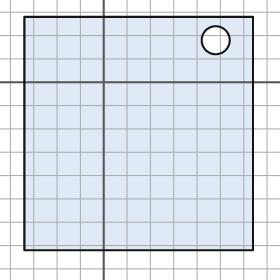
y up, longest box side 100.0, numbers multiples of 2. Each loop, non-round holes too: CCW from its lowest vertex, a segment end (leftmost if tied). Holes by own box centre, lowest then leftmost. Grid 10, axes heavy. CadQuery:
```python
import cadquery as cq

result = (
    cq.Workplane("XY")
    .moveTo(-34.0, -72.0)
    .lineTo(64.0, -72.0)
    .lineTo(64.0, 28.0)
    .lineTo(-34.0, 28.0)
    .close()
    .moveTo(48.0, 18.0)
    .circle(6.0)
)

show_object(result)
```